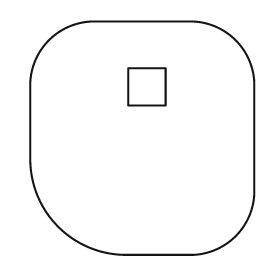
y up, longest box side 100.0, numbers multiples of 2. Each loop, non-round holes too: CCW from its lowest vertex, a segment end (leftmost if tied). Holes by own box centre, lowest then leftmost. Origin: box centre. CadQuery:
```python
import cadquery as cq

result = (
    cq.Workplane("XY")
    .moveTo(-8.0, -50.0)
    .lineTo(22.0, -50.0)
    .threePointArc((40.0, -42.0), (48.0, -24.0))
    .lineTo(48.0, 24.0)
    .threePointArc((40.0, 42.0), (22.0, 50.0))
    .lineTo(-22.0, 50.0)
    .threePointArc((-40.0, 42.0), (-48.0, 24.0))
    .lineTo(-48.0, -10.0)
    .threePointArc((-36.0, -38.0), (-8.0, -50.0))
    .close()
    .moveTo(-6.0, 14.0)
    .lineTo(10.0, 14.0)
    .lineTo(10.0, 30.0)
    .lineTo(-6.0, 30.0)
    .close()
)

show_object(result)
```